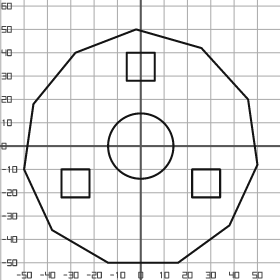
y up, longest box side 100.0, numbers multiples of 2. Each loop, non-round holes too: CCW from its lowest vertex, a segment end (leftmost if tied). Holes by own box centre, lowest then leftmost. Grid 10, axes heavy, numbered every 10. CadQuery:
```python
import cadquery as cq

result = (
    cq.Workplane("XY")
    .moveTo(-14.0, -50.0)
    .lineTo(16.0, -50.0)
    .lineTo(38.0, -34.0)
    .lineTo(50.0, -8.0)
    .lineTo(46.0, 20.0)
    .lineTo(26.0, 42.0)
    .lineTo(-2.0, 50.0)
    .lineTo(-28.0, 40.0)
    .lineTo(-46.0, 18.0)
    .lineTo(-50.0, -10.0)
    .lineTo(-38.0, -36.0)
    .close()
    .moveTo(-34.0, -22.0)
    .lineTo(-22.0, -22.0)
    .lineTo(-22.0, -10.0)
    .lineTo(-34.0, -10.0)
    .close()
    .moveTo(22.0, -22.0)
    .lineTo(34.0, -22.0)
    .lineTo(34.0, -10.0)
    .lineTo(22.0, -10.0)
    .close()
    .moveTo(0.0, 0.0)
    .circle(14.0)
    .moveTo(-6.0, 28.0)
    .lineTo(6.0, 28.0)
    .lineTo(6.0, 40.0)
    .lineTo(-6.0, 40.0)
    .close()
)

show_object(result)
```